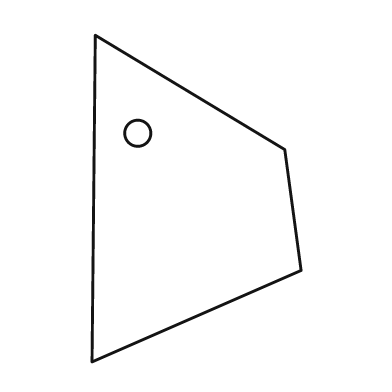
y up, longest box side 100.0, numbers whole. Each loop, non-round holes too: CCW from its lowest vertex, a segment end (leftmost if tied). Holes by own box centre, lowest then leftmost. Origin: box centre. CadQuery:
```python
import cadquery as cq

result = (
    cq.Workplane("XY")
    .moveTo(-32.0, -50.0)
    .lineTo(32.0, -22.0)
    .lineTo(27.0, 15.0)
    .lineTo(-31.0, 50.0)
    .close()
    .moveTo(-18.0, 20.0)
    .circle(4.0)
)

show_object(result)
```